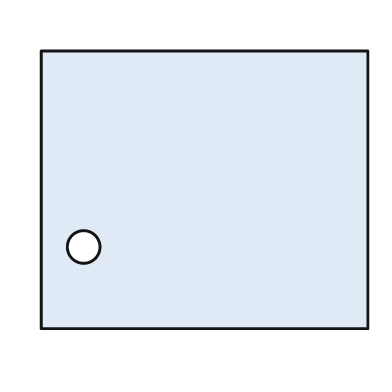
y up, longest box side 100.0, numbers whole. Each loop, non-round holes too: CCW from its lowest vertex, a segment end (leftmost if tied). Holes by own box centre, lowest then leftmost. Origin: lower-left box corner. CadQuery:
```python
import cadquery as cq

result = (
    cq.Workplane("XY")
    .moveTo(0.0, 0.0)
    .lineTo(100.0, 0.0)
    .lineTo(100.0, 85.0)
    .lineTo(0.0, 85.0)
    .close()
    .moveTo(13.0, 25.0)
    .circle(5.0)
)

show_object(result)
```